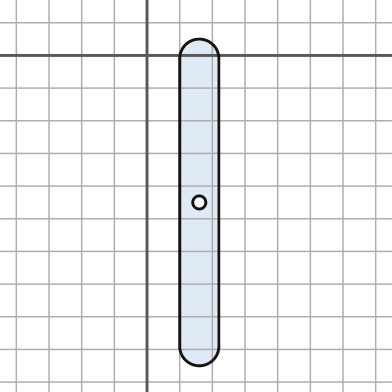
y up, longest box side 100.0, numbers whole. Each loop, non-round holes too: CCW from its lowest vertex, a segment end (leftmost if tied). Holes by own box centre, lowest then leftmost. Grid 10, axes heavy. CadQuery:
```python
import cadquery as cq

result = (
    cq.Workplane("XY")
    .moveTo(10.0, -89.0)
    .threePointArc((16.0, -95.0), (22.0, -89.0))
    .lineTo(22.0, -1.0)
    .threePointArc((16.0, 5.0), (10.0, -1.0))
    .close()
    .moveTo(16.0, -45.0)
    .circle(2.0)
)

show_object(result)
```